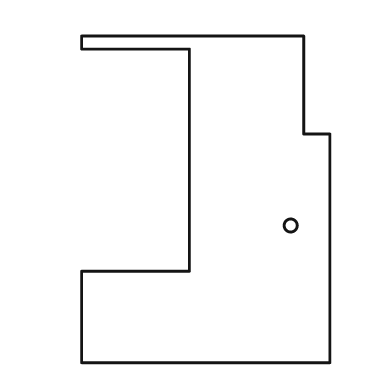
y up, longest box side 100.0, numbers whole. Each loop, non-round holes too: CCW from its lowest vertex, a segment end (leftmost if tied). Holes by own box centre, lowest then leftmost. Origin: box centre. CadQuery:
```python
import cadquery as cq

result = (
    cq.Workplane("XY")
    .moveTo(-38.0, -50.0)
    .lineTo(38.0, -50.0)
    .lineTo(38.0, 20.0)
    .lineTo(30.0, 20.0)
    .lineTo(30.0, 50.0)
    .lineTo(-38.0, 50.0)
    .lineTo(-38.0, 46.0)
    .lineTo(-5.0, 46.0)
    .lineTo(-5.0, -22.0)
    .lineTo(-38.0, -22.0)
    .close()
    .moveTo(26.0, -8.0)
    .circle(2.0)
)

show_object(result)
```